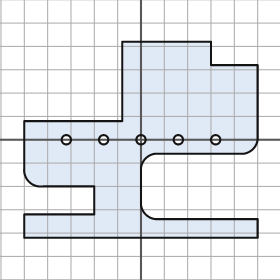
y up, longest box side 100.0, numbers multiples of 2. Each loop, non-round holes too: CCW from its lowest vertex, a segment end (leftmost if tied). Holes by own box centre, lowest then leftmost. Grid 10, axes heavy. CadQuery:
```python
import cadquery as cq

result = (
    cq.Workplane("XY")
    .moveTo(-50.0, -42.0)
    .lineTo(50.0, -42.0)
    .lineTo(50.0, -34.0)
    .lineTo(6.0, -34.0)
    .threePointArc((2.0, -32.0), (0.0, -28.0))
    .lineTo(0.0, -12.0)
    .threePointArc((2.0, -8.0), (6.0, -6.0))
    .lineTo(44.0, -6.0)
    .threePointArc((48.0, -4.0), (50.0, 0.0))
    .lineTo(50.0, 32.0)
    .lineTo(30.0, 32.0)
    .lineTo(30.0, 42.0)
    .lineTo(-8.0, 42.0)
    .lineTo(-8.0, 8.0)
    .lineTo(-50.0, 8.0)
    .lineTo(-50.0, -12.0)
    .threePointArc((-48.0, -18.0), (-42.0, -20.0))
    .lineTo(-20.0, -20.0)
    .lineTo(-20.0, -32.0)
    .lineTo(-50.0, -32.0)
    .close()
    .moveTo(-32.0, 0.0)
    .circle(2.0)
    .moveTo(-16.0, 0.0)
    .circle(2.0)
    .moveTo(0.0, 0.0)
    .circle(2.0)
    .moveTo(16.0, 0.0)
    .circle(2.0)
    .moveTo(32.0, 0.0)
    .circle(2.0)
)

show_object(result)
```